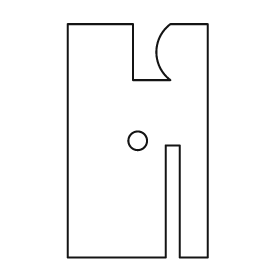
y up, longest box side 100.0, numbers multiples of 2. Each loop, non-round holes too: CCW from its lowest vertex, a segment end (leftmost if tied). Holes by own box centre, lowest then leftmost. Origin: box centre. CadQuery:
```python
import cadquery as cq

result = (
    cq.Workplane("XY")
    .moveTo(-30.0, -50.0)
    .lineTo(12.0, -50.0)
    .lineTo(12.0, -2.0)
    .lineTo(18.0, -2.0)
    .lineTo(18.0, -50.0)
    .lineTo(30.0, -50.0)
    .lineTo(30.0, 50.0)
    .lineTo(14.0, 50.0)
    .threePointArc((8.0, 38.0), (14.0, 26.0))
    .lineTo(-2.0, 26.0)
    .lineTo(-2.0, 50.0)
    .lineTo(-30.0, 50.0)
    .close()
    .moveTo(0.0, 0.0)
    .circle(4.0)
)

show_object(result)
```